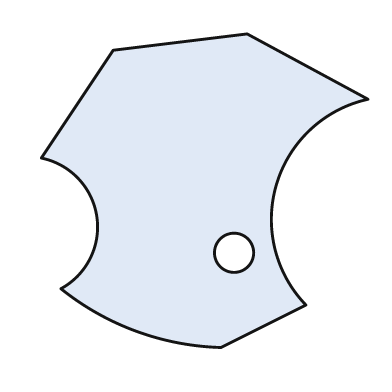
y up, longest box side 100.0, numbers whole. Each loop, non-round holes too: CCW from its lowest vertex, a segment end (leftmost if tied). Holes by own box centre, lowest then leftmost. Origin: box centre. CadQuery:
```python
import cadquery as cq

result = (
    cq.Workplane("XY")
    .moveTo(5.0, -48.0)
    .lineTo(31.0, -35.0)
    .threePointArc((22.0, 2.0), (50.0, 28.0))
    .lineTo(13.0, 48.0)
    .lineTo(-28.0, 43.0)
    .lineTo(-50.0, 10.0)
    .threePointArc((-33.0, -8.0), (-44.0, -30.0))
    .threePointArc((-21.0, -43.0), (5.0, -48.0))
    .close()
    .moveTo(9.0, -19.0)
    .circle(6.0)
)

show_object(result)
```